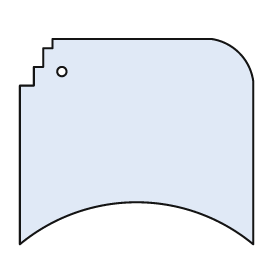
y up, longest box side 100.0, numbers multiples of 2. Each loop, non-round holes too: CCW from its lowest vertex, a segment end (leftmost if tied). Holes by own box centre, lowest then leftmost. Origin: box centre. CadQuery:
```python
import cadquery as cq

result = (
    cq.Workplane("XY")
    .moveTo(-50.0, -44.0)
    .threePointArc((0.0, -26.0), (50.0, -44.0))
    .lineTo(50.0, 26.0)
    .threePointArc((44.0, 38.0), (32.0, 44.0))
    .lineTo(-36.0, 44.0)
    .lineTo(-36.0, 40.0)
    .lineTo(-40.0, 40.0)
    .lineTo(-40.0, 32.0)
    .lineTo(-44.0, 32.0)
    .lineTo(-44.0, 24.0)
    .lineTo(-50.0, 24.0)
    .close()
    .moveTo(-32.0, 30.0)
    .circle(2.0)
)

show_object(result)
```